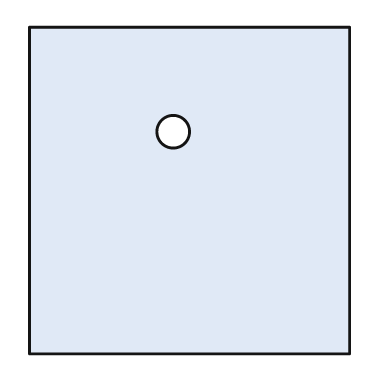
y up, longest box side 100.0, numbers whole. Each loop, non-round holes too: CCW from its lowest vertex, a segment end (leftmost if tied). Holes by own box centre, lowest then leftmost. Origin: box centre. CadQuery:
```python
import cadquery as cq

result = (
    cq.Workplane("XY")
    .moveTo(-49.0, -50.0)
    .lineTo(49.0, -50.0)
    .lineTo(49.0, 50.0)
    .lineTo(-49.0, 50.0)
    .close()
    .moveTo(-5.0, 18.0)
    .circle(5.0)
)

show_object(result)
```